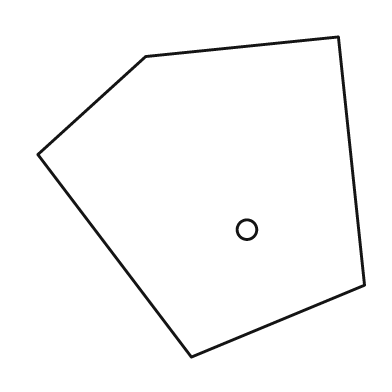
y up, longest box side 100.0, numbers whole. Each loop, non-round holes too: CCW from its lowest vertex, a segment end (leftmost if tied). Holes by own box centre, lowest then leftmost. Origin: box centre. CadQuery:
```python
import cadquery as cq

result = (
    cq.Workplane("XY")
    .moveTo(-3.0, -49.0)
    .lineTo(50.0, -27.0)
    .lineTo(42.0, 49.0)
    .lineTo(-17.0, 43.0)
    .lineTo(-50.0, 13.0)
    .close()
    .moveTo(14.0, -10.0)
    .circle(3.0)
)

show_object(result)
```